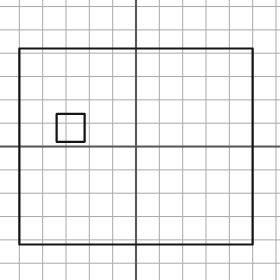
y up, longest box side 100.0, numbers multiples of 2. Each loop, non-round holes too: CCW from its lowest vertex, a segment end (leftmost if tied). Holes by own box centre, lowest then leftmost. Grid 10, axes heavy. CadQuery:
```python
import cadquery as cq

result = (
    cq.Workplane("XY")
    .moveTo(-50.0, -42.0)
    .lineTo(50.0, -42.0)
    .lineTo(50.0, 42.0)
    .lineTo(-50.0, 42.0)
    .close()
    .moveTo(-34.0, 2.0)
    .lineTo(-22.0, 2.0)
    .lineTo(-22.0, 14.0)
    .lineTo(-34.0, 14.0)
    .close()
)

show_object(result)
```